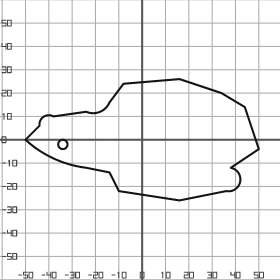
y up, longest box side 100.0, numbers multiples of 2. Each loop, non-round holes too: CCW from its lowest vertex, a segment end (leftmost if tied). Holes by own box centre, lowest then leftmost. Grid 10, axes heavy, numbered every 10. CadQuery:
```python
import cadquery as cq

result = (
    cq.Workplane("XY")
    .moveTo(16.0, -26.0)
    .lineTo(36.0, -22.0)
    .threePointArc((42.0, -18.0), (38.0, -12.0))
    .lineTo(50.0, -4.0)
    .lineTo(44.0, 14.0)
    .lineTo(34.0, 20.0)
    .lineTo(16.0, 26.0)
    .lineTo(-8.0, 24.0)
    .lineTo(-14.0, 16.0)
    .threePointArc((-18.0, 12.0), (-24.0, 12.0))
    .lineTo(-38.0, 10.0)
    .threePointArc((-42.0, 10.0), (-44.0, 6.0))
    .lineTo(-50.0, 0.0)
    .threePointArc((-38.0, -8.0), (-24.0, -12.0))
    .lineTo(-14.0, -14.0)
    .lineTo(-10.0, -22.0)
    .close()
    .moveTo(-34.0, -2.0)
    .circle(2.0)
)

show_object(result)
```